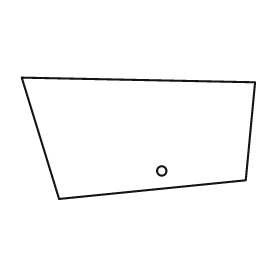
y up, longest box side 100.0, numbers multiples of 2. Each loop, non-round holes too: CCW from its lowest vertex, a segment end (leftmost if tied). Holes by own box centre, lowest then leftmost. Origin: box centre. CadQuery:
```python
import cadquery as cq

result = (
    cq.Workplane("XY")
    .moveTo(-34.0, -26.0)
    .lineTo(46.0, -18.0)
    .lineTo(50.0, 24.0)
    .lineTo(-50.0, 26.0)
    .close()
    .moveTo(10.0, -14.0)
    .circle(2.0)
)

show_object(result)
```